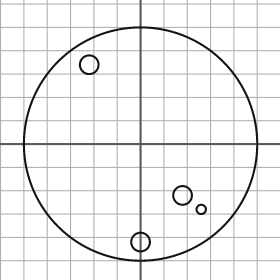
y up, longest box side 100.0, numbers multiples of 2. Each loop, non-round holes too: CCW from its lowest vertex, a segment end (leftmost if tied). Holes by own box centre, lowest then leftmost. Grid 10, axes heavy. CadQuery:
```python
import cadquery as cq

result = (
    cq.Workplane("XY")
    .moveTo(0.0, 0.0)
    .circle(50.0)
    .moveTo(0.0, -42.0)
    .circle(4.0)
    .moveTo(26.0, -28.0)
    .circle(2.0)
    .moveTo(18.0, -22.0)
    .circle(4.0)
    .moveTo(-22.0, 34.0)
    .circle(4.0)
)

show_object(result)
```